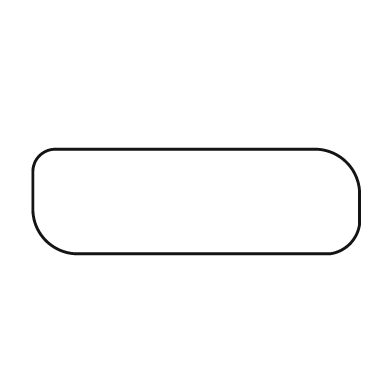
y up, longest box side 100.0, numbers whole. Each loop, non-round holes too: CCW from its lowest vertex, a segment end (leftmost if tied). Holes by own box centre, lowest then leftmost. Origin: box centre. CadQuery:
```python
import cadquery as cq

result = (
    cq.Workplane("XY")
    .moveTo(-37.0, -16.0)
    .lineTo(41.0, -16.0)
    .threePointArc((47.0, -13.0), (50.0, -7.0))
    .lineTo(50.0, 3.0)
    .threePointArc((46.0, 12.0), (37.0, 16.0))
    .lineTo(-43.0, 16.0)
    .threePointArc((-48.0, 14.0), (-50.0, 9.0))
    .lineTo(-50.0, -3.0)
    .threePointArc((-46.0, -12.0), (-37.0, -16.0))
    .close()
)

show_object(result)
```